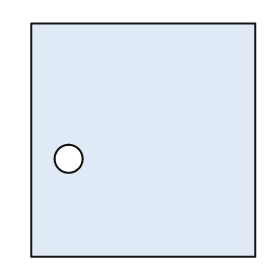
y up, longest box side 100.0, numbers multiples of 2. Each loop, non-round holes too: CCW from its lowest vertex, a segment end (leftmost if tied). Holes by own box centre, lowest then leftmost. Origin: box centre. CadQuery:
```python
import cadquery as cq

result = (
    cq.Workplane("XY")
    .moveTo(-48.0, -50.0)
    .lineTo(48.0, -50.0)
    .lineTo(48.0, 50.0)
    .lineTo(-48.0, 50.0)
    .close()
    .moveTo(-32.0, -8.0)
    .circle(6.0)
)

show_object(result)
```